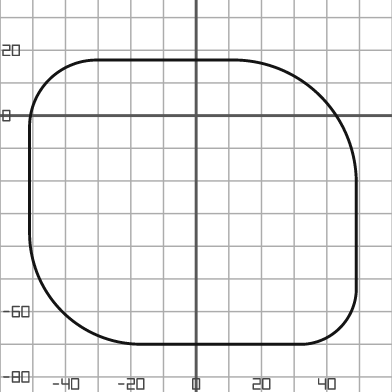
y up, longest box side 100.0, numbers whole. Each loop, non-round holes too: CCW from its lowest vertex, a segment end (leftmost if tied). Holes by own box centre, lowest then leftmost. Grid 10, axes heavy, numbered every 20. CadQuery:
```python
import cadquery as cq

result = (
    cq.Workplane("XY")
    .moveTo(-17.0, -70.0)
    .lineTo(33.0, -70.0)
    .threePointArc((44.0, -65.0), (49.0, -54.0))
    .lineTo(49.0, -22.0)
    .threePointArc((38.0, 6.0), (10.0, 17.0))
    .lineTo(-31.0, 17.0)
    .threePointArc((-45.0, 11.0), (-51.0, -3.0))
    .lineTo(-51.0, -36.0)
    .threePointArc((-41.0, -60.0), (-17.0, -70.0))
    .close()
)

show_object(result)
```